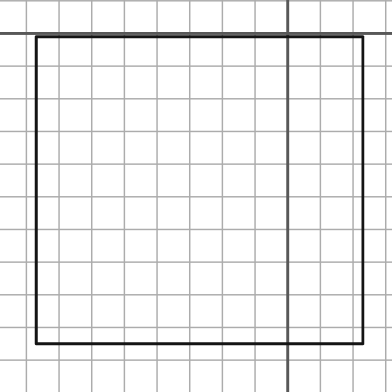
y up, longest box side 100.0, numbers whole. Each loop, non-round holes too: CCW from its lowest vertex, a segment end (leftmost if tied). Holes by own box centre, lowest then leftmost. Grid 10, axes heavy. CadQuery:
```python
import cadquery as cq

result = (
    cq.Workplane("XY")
    .moveTo(-77.0, -95.0)
    .lineTo(23.0, -95.0)
    .lineTo(23.0, -1.0)
    .lineTo(-77.0, -1.0)
    .close()
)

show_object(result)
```